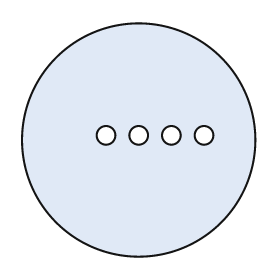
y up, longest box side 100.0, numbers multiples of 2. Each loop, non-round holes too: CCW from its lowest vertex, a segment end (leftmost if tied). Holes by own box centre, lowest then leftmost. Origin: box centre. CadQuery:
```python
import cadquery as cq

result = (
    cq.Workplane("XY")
    .moveTo(0.0, 0.0)
    .circle(50.0)
    .moveTo(-14.0, 2.0)
    .circle(4.0)
    .moveTo(0.0, 2.0)
    .circle(4.0)
    .moveTo(14.0, 2.0)
    .circle(4.0)
    .moveTo(28.0, 2.0)
    .circle(4.0)
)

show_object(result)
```